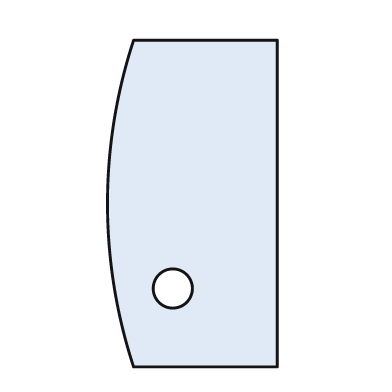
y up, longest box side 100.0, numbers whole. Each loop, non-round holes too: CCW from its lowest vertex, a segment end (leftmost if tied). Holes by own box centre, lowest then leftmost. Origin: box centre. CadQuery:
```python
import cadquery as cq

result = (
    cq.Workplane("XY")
    .moveTo(-18.0, -50.0)
    .lineTo(26.0, -50.0)
    .lineTo(26.0, 50.0)
    .lineTo(-18.0, 50.0)
    .threePointArc((-26.0, 0.0), (-18.0, -50.0))
    .close()
    .moveTo(-6.0, -26.0)
    .circle(6.0)
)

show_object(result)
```